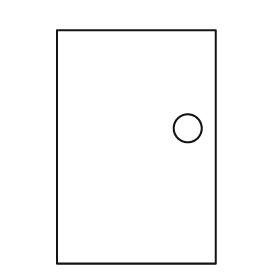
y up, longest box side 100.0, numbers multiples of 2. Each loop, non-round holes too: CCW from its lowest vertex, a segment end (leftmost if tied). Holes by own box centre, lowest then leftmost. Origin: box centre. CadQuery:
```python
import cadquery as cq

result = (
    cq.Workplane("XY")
    .moveTo(-34.0, -50.0)
    .lineTo(34.0, -50.0)
    .lineTo(34.0, 50.0)
    .lineTo(-34.0, 50.0)
    .close()
    .moveTo(22.0, 8.0)
    .circle(6.0)
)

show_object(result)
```